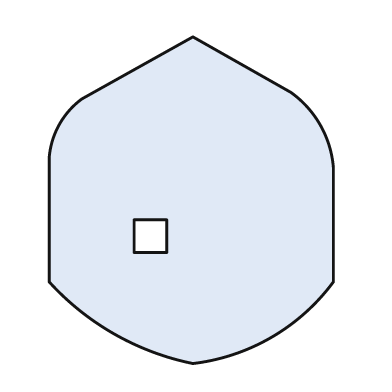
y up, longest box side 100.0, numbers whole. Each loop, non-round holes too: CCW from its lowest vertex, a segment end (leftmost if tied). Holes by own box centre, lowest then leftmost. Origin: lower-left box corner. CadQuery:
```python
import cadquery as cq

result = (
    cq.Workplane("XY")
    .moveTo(44.0, 0.0)
    .threePointArc((68.0, 8.0), (87.0, 25.0))
    .lineTo(87.0, 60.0)
    .threePointArc((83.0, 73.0), (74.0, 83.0))
    .lineTo(44.0, 100.0)
    .lineTo(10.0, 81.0)
    .threePointArc((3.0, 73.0), (0.0, 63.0))
    .lineTo(0.0, 25.0)
    .threePointArc((20.0, 9.0), (44.0, 0.0))
    .close()
    .moveTo(26.0, 34.0)
    .lineTo(36.0, 34.0)
    .lineTo(36.0, 44.0)
    .lineTo(26.0, 44.0)
    .close()
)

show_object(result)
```